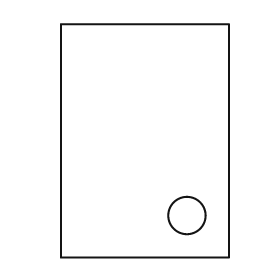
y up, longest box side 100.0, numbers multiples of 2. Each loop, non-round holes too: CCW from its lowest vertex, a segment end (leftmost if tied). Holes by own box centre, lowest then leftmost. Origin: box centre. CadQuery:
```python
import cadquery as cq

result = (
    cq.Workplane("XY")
    .moveTo(-36.0, -50.0)
    .lineTo(36.0, -50.0)
    .lineTo(36.0, 50.0)
    .lineTo(-36.0, 50.0)
    .close()
    .moveTo(18.0, -32.0)
    .circle(8.0)
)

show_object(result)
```